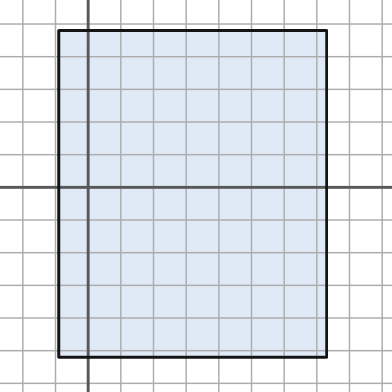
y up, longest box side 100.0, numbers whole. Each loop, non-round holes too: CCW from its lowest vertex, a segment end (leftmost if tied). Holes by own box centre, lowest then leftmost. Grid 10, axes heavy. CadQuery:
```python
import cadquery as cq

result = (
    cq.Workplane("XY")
    .moveTo(-9.0, -52.0)
    .lineTo(73.0, -52.0)
    .lineTo(73.0, 48.0)
    .lineTo(-9.0, 48.0)
    .close()
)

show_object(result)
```